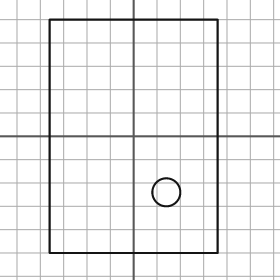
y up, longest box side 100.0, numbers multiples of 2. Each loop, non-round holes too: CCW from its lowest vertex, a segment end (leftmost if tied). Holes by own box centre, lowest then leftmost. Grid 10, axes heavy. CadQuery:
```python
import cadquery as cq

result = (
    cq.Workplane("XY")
    .moveTo(-36.0, -50.0)
    .lineTo(36.0, -50.0)
    .lineTo(36.0, 50.0)
    .lineTo(-36.0, 50.0)
    .close()
    .moveTo(14.0, -24.0)
    .circle(6.0)
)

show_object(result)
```